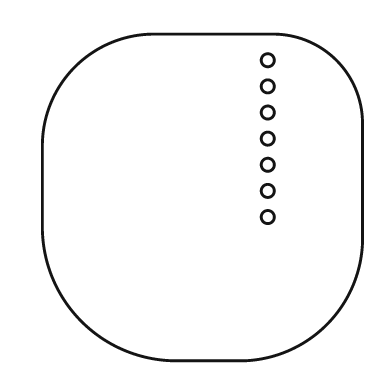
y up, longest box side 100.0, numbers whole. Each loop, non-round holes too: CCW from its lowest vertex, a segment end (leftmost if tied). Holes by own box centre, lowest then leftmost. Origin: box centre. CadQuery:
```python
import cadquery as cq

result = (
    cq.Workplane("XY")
    .moveTo(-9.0, -50.0)
    .lineTo(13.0, -50.0)
    .threePointArc((38.0, -39.0), (49.0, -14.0))
    .lineTo(49.0, 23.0)
    .threePointArc((41.0, 42.0), (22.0, 50.0))
    .lineTo(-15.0, 50.0)
    .threePointArc((-39.0, 40.0), (-49.0, 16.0))
    .lineTo(-49.0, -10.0)
    .threePointArc((-37.0, -38.0), (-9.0, -50.0))
    .close()
    .moveTo(20.0, -6.0)
    .circle(2.0)
    .moveTo(20.0, 2.0)
    .circle(2.0)
    .moveTo(20.0, 10.0)
    .circle(2.0)
    .moveTo(20.0, 18.0)
    .circle(2.0)
    .moveTo(20.0, 26.0)
    .circle(2.0)
    .moveTo(20.0, 34.0)
    .circle(2.0)
    .moveTo(20.0, 42.0)
    .circle(2.0)
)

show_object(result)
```